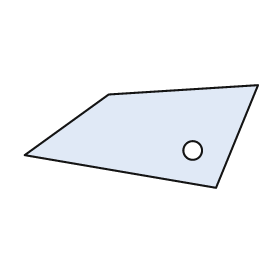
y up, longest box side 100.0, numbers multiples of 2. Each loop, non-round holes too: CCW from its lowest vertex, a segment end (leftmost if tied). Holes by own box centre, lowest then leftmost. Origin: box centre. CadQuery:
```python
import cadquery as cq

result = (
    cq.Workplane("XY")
    .moveTo(32.0, -22.0)
    .lineTo(50.0, 22.0)
    .lineTo(-14.0, 18.0)
    .lineTo(-50.0, -8.0)
    .close()
    .moveTo(22.0, -6.0)
    .circle(4.0)
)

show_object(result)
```